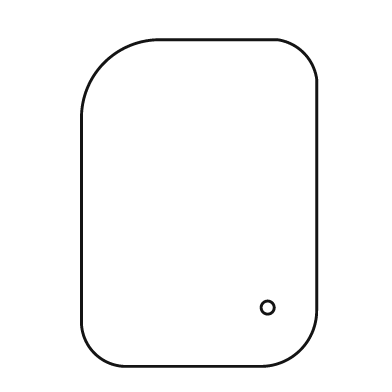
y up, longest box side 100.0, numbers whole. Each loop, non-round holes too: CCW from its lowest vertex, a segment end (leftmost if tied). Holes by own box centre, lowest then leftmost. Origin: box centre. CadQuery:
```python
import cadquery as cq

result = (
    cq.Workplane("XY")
    .moveTo(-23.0, -50.0)
    .lineTo(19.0, -50.0)
    .threePointArc((31.0, -45.0), (36.0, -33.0))
    .lineTo(36.0, 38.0)
    .threePointArc((32.0, 46.0), (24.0, 50.0))
    .lineTo(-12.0, 50.0)
    .threePointArc((-29.0, 43.0), (-36.0, 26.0))
    .lineTo(-36.0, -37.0)
    .threePointArc((-32.0, -46.0), (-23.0, -50.0))
    .close()
    .moveTo(21.0, -32.0)
    .circle(2.0)
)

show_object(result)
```